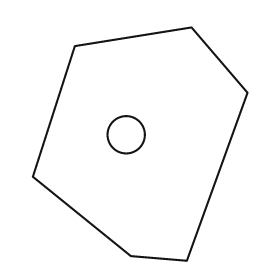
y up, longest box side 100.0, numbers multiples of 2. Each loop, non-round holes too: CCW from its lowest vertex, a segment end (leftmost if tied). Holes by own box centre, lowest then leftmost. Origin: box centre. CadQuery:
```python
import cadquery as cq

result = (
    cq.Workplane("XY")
    .moveTo(20.0, -50.0)
    .lineTo(46.0, 22.0)
    .lineTo(22.0, 50.0)
    .lineTo(-28.0, 42.0)
    .lineTo(-46.0, -14.0)
    .lineTo(-4.0, -48.0)
    .close()
    .moveTo(-6.0, 4.0)
    .circle(8.0)
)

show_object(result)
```